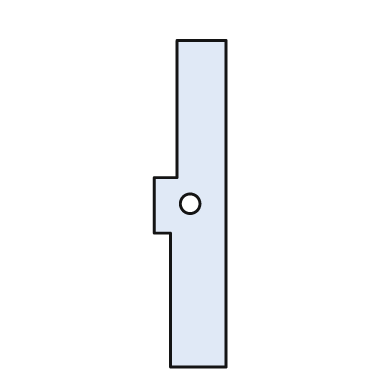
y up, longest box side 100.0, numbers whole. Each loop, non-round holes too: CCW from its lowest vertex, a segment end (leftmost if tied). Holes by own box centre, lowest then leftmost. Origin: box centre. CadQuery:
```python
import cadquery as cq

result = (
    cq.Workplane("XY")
    .moveTo(-6.0, -50.0)
    .lineTo(11.0, -50.0)
    .lineTo(11.0, 50.0)
    .lineTo(-4.0, 50.0)
    .lineTo(-4.0, 8.0)
    .lineTo(-11.0, 8.0)
    .lineTo(-11.0, -9.0)
    .lineTo(-6.0, -9.0)
    .close()
    .moveTo(0.0, 0.0)
    .circle(3.0)
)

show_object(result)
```